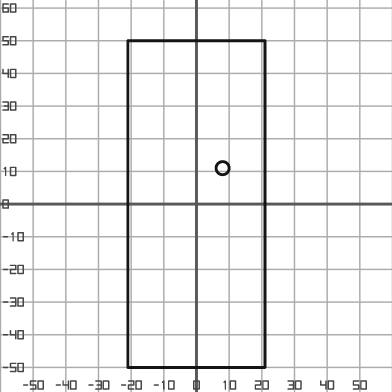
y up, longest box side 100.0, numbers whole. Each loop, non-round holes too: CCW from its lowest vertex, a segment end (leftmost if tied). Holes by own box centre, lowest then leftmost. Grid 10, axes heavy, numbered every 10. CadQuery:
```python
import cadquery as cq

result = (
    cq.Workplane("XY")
    .moveTo(-21.0, -50.0)
    .lineTo(21.0, -50.0)
    .lineTo(21.0, 50.0)
    .lineTo(-21.0, 50.0)
    .close()
    .moveTo(8.0, 11.0)
    .circle(2.0)
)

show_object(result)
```